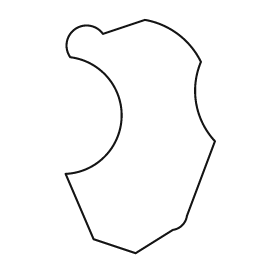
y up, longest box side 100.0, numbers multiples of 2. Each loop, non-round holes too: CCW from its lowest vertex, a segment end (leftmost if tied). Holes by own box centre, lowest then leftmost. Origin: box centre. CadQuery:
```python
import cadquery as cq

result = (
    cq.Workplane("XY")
    .moveTo(-2.0, -50.0)
    .lineTo(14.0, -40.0)
    .threePointArc((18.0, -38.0), (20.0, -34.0))
    .lineTo(32.0, -2.0)
    .threePointArc((24.0, 14.0), (26.0, 32.0))
    .threePointArc((16.0, 44.0), (2.0, 50.0))
    .lineTo(-16.0, 44.0)
    .threePointArc((-28.0, 46.0), (-30.0, 34.0))
    .threePointArc((-8.0, 8.0), (-32.0, -16.0))
    .lineTo(-20.0, -44.0)
    .close()
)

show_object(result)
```